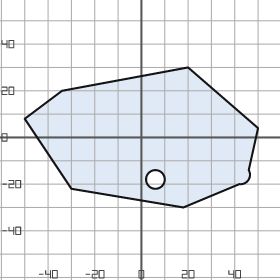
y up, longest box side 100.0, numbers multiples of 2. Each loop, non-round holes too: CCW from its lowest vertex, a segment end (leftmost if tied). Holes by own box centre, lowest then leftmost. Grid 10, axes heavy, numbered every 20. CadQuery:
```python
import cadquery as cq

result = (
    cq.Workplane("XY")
    .moveTo(18.0, -30.0)
    .lineTo(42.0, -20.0)
    .threePointArc((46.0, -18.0), (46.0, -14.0))
    .lineTo(50.0, 4.0)
    .lineTo(20.0, 30.0)
    .lineTo(-34.0, 20.0)
    .lineTo(-50.0, 8.0)
    .lineTo(-30.0, -22.0)
    .close()
    .moveTo(6.0, -18.0)
    .circle(4.0)
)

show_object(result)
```